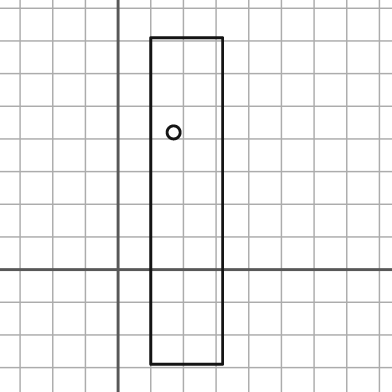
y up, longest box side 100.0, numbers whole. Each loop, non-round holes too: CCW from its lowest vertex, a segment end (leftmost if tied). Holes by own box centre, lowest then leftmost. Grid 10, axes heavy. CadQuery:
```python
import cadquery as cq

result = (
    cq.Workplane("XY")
    .moveTo(10.0, -29.0)
    .lineTo(32.0, -29.0)
    .lineTo(32.0, 71.0)
    .lineTo(10.0, 71.0)
    .close()
    .moveTo(17.0, 42.0)
    .circle(2.0)
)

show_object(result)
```